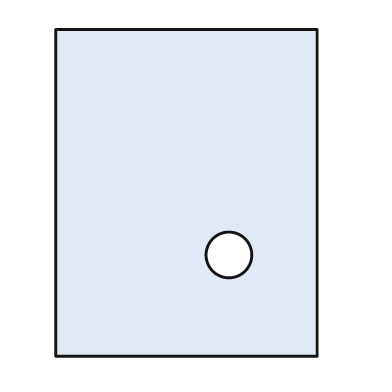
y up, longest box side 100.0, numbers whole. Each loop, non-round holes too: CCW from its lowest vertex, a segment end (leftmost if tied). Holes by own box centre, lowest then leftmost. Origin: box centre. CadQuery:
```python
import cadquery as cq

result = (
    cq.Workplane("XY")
    .moveTo(-40.0, -50.0)
    .lineTo(40.0, -50.0)
    .lineTo(40.0, 50.0)
    .lineTo(-40.0, 50.0)
    .close()
    .moveTo(13.0, -19.0)
    .circle(7.0)
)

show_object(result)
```